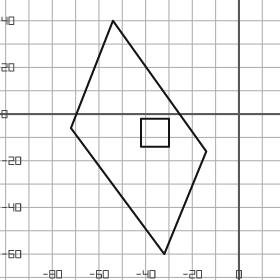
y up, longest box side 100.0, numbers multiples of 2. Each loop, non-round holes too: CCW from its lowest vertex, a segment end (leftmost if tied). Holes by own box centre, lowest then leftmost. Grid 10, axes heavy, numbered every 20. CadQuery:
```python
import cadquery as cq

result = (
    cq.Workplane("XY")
    .moveTo(-32.0, -60.0)
    .lineTo(-14.0, -16.0)
    .lineTo(-54.0, 40.0)
    .lineTo(-72.0, -6.0)
    .close()
    .moveTo(-42.0, -14.0)
    .lineTo(-30.0, -14.0)
    .lineTo(-30.0, -2.0)
    .lineTo(-42.0, -2.0)
    .close()
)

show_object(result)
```